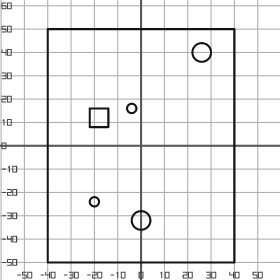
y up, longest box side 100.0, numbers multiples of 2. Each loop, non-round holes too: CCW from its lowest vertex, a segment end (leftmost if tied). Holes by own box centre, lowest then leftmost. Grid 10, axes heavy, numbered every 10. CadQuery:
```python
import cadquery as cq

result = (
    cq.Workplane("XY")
    .moveTo(-40.0, -50.0)
    .lineTo(40.0, -50.0)
    .lineTo(40.0, 50.0)
    .lineTo(-40.0, 50.0)
    .close()
    .moveTo(0.0, -32.0)
    .circle(4.0)
    .moveTo(-20.0, -24.0)
    .circle(2.0)
    .moveTo(-22.0, 8.0)
    .lineTo(-14.0, 8.0)
    .lineTo(-14.0, 16.0)
    .lineTo(-22.0, 16.0)
    .close()
    .moveTo(-4.0, 16.0)
    .circle(2.0)
    .moveTo(26.0, 40.0)
    .circle(4.0)
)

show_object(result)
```